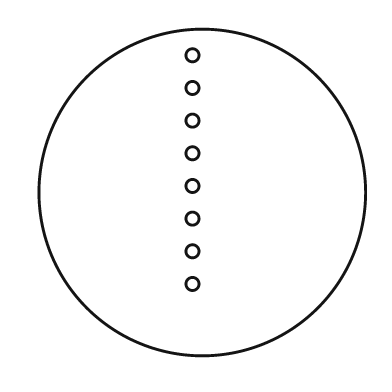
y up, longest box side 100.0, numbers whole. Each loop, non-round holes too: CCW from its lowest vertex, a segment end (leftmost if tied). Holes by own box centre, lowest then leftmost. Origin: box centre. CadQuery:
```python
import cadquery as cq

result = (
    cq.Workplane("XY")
    .moveTo(0.0, 0.0)
    .circle(50.0)
    .moveTo(-3.0, -28.0)
    .circle(2.0)
    .moveTo(-3.0, -18.0)
    .circle(2.0)
    .moveTo(-3.0, -8.0)
    .circle(2.0)
    .moveTo(-3.0, 2.0)
    .circle(2.0)
    .moveTo(-3.0, 12.0)
    .circle(2.0)
    .moveTo(-3.0, 22.0)
    .circle(2.0)
    .moveTo(-3.0, 32.0)
    .circle(2.0)
    .moveTo(-3.0, 42.0)
    .circle(2.0)
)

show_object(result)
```